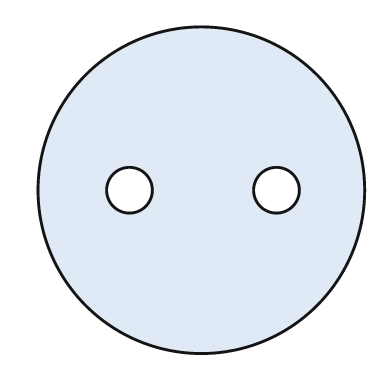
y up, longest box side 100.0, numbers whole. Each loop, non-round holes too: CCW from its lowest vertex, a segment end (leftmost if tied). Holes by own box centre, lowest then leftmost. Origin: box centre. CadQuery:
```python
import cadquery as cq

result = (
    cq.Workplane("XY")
    .moveTo(0.0, 0.0)
    .circle(50.0)
    .moveTo(-22.0, 0.0)
    .circle(7.0)
    .moveTo(23.0, 0.0)
    .circle(7.0)
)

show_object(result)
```